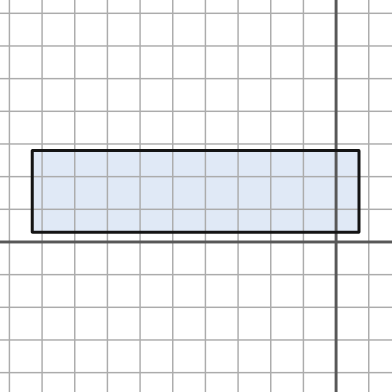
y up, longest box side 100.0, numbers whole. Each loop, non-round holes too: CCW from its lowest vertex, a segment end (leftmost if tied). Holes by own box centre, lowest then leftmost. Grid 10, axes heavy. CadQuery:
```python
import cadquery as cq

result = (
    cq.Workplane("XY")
    .moveTo(-93.0, 3.0)
    .lineTo(7.0, 3.0)
    .lineTo(7.0, 28.0)
    .lineTo(-93.0, 28.0)
    .close()
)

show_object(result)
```